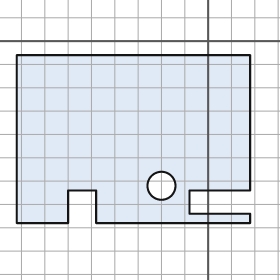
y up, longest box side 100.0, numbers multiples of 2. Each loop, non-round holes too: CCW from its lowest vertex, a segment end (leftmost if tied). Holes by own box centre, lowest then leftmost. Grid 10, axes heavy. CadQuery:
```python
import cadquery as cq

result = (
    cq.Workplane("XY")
    .moveTo(-82.0, -78.0)
    .lineTo(-60.0, -78.0)
    .lineTo(-60.0, -64.0)
    .lineTo(-48.0, -64.0)
    .lineTo(-48.0, -78.0)
    .lineTo(18.0, -78.0)
    .lineTo(18.0, -74.0)
    .lineTo(-8.0, -74.0)
    .lineTo(-8.0, -64.0)
    .lineTo(18.0, -64.0)
    .lineTo(18.0, -6.0)
    .lineTo(-82.0, -6.0)
    .close()
    .moveTo(-20.0, -62.0)
    .circle(6.0)
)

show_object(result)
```